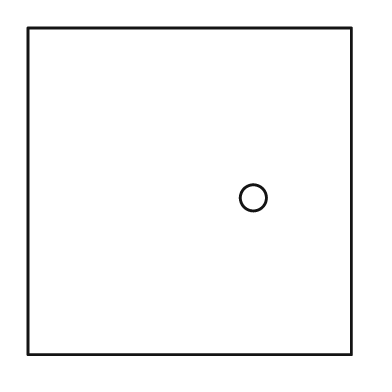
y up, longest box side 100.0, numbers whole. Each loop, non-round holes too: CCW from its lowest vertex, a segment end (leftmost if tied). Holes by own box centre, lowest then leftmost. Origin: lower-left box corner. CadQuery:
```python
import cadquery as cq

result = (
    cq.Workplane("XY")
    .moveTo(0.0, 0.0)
    .lineTo(99.0, 0.0)
    .lineTo(99.0, 100.0)
    .lineTo(0.0, 100.0)
    .close()
    .moveTo(69.0, 48.0)
    .circle(4.0)
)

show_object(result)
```